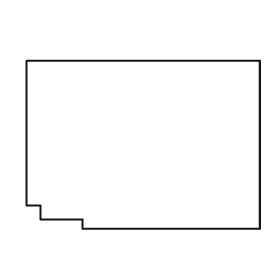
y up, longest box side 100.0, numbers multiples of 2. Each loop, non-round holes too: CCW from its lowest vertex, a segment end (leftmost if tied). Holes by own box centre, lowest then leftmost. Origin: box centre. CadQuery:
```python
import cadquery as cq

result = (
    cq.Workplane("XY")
    .moveTo(-26.0, -36.0)
    .lineTo(50.0, -36.0)
    .lineTo(50.0, 36.0)
    .lineTo(-50.0, 36.0)
    .lineTo(-50.0, -26.0)
    .lineTo(-44.0, -26.0)
    .lineTo(-44.0, -32.0)
    .lineTo(-26.0, -32.0)
    .close()
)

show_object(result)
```